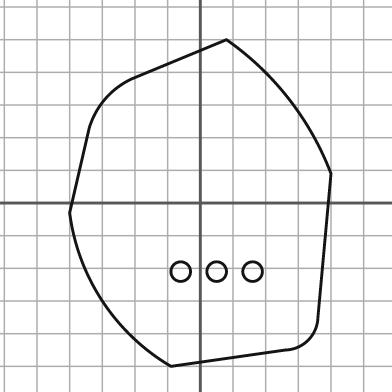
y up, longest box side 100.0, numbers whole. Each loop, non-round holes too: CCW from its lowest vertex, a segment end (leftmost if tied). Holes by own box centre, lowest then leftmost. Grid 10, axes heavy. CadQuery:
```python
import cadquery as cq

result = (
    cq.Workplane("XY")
    .moveTo(-9.0, -50.0)
    .lineTo(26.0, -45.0)
    .threePointArc((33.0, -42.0), (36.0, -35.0))
    .lineTo(40.0, 9.0)
    .threePointArc((27.0, 32.0), (8.0, 50.0))
    .lineTo(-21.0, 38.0)
    .threePointArc((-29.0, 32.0), (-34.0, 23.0))
    .lineTo(-40.0, -3.0)
    .threePointArc((-30.0, -30.0), (-9.0, -50.0))
    .close()
    .moveTo(-6.0, -21.0)
    .circle(3.0)
    .moveTo(5.0, -21.0)
    .circle(3.0)
    .moveTo(16.0, -21.0)
    .circle(3.0)
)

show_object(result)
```